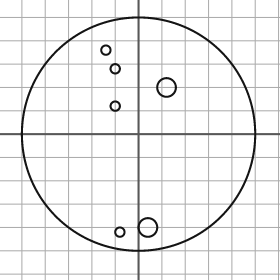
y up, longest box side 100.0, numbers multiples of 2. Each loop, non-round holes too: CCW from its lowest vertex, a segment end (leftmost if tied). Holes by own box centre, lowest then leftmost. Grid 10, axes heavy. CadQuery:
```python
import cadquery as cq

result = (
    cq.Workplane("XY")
    .moveTo(0.0, 0.0)
    .circle(50.0)
    .moveTo(-8.0, -42.0)
    .circle(2.0)
    .moveTo(4.0, -40.0)
    .circle(4.0)
    .moveTo(-10.0, 12.0)
    .circle(2.0)
    .moveTo(12.0, 20.0)
    .circle(4.0)
    .moveTo(-10.0, 28.0)
    .circle(2.0)
    .moveTo(-14.0, 36.0)
    .circle(2.0)
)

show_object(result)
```